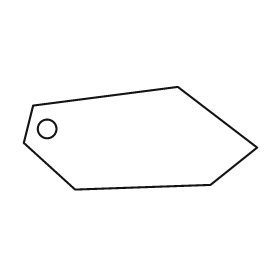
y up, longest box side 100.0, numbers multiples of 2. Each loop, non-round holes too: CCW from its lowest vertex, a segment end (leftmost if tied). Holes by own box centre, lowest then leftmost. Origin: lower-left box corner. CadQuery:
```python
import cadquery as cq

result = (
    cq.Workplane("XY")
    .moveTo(22.0, 0.0)
    .lineTo(80.0, 2.0)
    .lineTo(100.0, 18.0)
    .lineTo(66.0, 44.0)
    .lineTo(4.0, 36.0)
    .lineTo(0.0, 20.0)
    .close()
    .moveTo(10.0, 26.0)
    .circle(4.0)
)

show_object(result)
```